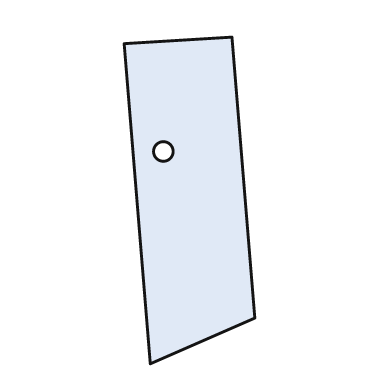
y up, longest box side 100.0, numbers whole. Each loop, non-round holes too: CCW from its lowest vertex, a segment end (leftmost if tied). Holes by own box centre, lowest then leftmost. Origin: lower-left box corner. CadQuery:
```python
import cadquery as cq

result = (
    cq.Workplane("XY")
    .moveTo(8.0, 0.0)
    .lineTo(40.0, 14.0)
    .lineTo(33.0, 100.0)
    .lineTo(0.0, 98.0)
    .close()
    .moveTo(12.0, 65.0)
    .circle(3.0)
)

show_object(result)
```